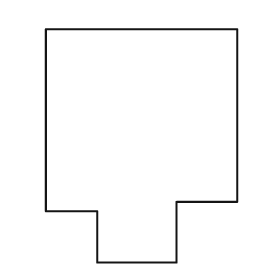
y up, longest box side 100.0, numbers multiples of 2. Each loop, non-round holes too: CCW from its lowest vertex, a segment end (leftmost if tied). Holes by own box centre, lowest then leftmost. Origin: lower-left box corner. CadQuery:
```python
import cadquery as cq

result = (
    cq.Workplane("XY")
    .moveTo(22.0, 0.0)
    .lineTo(56.0, 0.0)
    .lineTo(56.0, 26.0)
    .lineTo(82.0, 26.0)
    .lineTo(82.0, 100.0)
    .lineTo(0.0, 100.0)
    .lineTo(0.0, 22.0)
    .lineTo(22.0, 22.0)
    .close()
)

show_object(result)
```